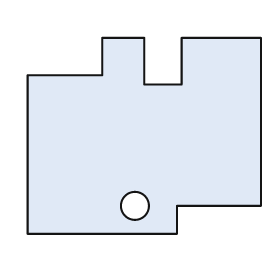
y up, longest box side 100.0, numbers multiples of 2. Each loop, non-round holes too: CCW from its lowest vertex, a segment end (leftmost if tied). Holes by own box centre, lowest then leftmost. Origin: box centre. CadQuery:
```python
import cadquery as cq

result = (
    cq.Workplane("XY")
    .moveTo(-50.0, -42.0)
    .lineTo(14.0, -42.0)
    .lineTo(14.0, -30.0)
    .lineTo(50.0, -30.0)
    .lineTo(50.0, 42.0)
    .lineTo(16.0, 42.0)
    .lineTo(16.0, 22.0)
    .lineTo(0.0, 22.0)
    .lineTo(0.0, 42.0)
    .lineTo(-18.0, 42.0)
    .lineTo(-18.0, 26.0)
    .lineTo(-50.0, 26.0)
    .close()
    .moveTo(-4.0, -30.0)
    .circle(6.0)
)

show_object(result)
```